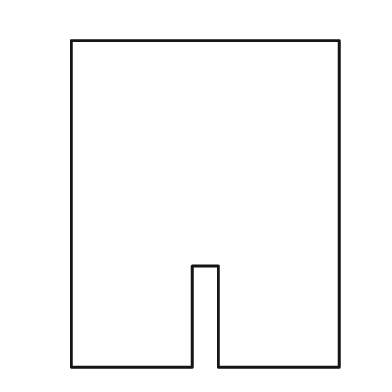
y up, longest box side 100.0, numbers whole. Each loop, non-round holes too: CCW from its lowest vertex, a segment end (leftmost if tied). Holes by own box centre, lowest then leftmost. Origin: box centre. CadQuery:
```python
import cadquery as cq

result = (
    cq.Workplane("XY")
    .moveTo(-41.0, -50.0)
    .lineTo(-4.0, -50.0)
    .lineTo(-4.0, -19.0)
    .lineTo(4.0, -19.0)
    .lineTo(4.0, -50.0)
    .lineTo(41.0, -50.0)
    .lineTo(41.0, 50.0)
    .lineTo(-41.0, 50.0)
    .close()
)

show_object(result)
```